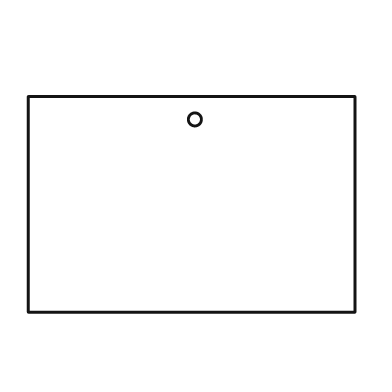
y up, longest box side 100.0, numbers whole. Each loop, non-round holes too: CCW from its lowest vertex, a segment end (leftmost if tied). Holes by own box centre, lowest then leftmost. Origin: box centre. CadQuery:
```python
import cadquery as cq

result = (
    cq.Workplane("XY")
    .moveTo(-50.0, -33.0)
    .lineTo(50.0, -33.0)
    .lineTo(50.0, 33.0)
    .lineTo(-50.0, 33.0)
    .close()
    .moveTo(1.0, 26.0)
    .circle(2.0)
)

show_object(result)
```